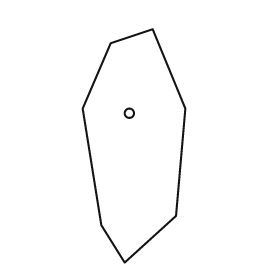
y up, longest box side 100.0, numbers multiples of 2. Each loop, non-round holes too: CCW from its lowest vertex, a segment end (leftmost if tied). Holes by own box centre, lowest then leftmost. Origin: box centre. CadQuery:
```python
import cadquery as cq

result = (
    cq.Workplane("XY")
    .moveTo(-4.0, -50.0)
    .lineTo(18.0, -30.0)
    .lineTo(22.0, 16.0)
    .lineTo(8.0, 50.0)
    .lineTo(-10.0, 44.0)
    .lineTo(-22.0, 16.0)
    .lineTo(-14.0, -34.0)
    .close()
    .moveTo(-2.0, 14.0)
    .circle(2.0)
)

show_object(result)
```